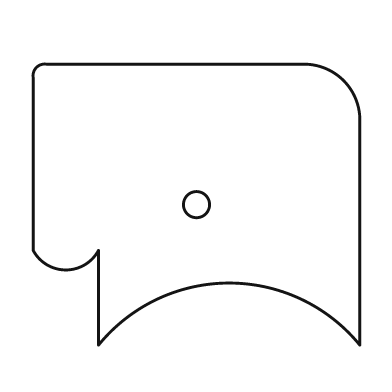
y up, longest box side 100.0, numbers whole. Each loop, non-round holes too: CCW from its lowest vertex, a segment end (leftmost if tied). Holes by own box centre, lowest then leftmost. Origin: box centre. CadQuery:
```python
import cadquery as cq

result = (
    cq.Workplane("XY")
    .moveTo(-30.0, -43.0)
    .threePointArc((10.0, -24.0), (50.0, -43.0))
    .lineTo(50.0, 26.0)
    .threePointArc((45.0, 38.0), (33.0, 43.0))
    .lineTo(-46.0, 43.0)
    .threePointArc((-49.0, 42.0), (-50.0, 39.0))
    .lineTo(-50.0, -14.0)
    .threePointArc((-40.0, -20.0), (-30.0, -14.0))
    .close()
    .moveTo(0.0, 0.0)
    .circle(4.0)
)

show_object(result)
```